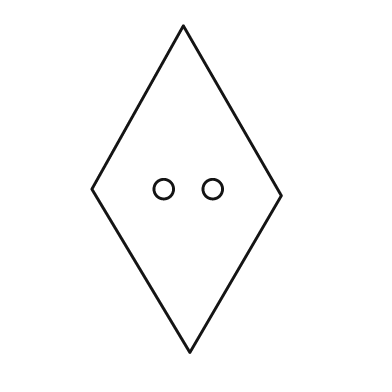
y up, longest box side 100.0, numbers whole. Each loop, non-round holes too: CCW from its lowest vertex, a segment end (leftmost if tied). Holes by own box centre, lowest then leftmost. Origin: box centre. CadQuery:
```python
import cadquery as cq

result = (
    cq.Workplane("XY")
    .moveTo(1.0, -50.0)
    .lineTo(29.0, -2.0)
    .lineTo(-1.0, 50.0)
    .lineTo(-29.0, 0.0)
    .close()
    .moveTo(-7.0, 0.0)
    .circle(3.0)
    .moveTo(8.0, 0.0)
    .circle(3.0)
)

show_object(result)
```